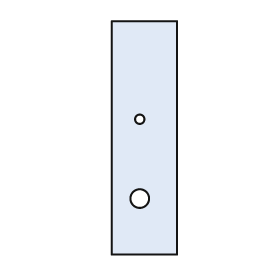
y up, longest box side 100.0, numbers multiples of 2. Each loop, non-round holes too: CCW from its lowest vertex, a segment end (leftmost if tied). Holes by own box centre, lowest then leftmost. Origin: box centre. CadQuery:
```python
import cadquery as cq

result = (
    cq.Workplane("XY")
    .moveTo(-14.0, -50.0)
    .lineTo(14.0, -50.0)
    .lineTo(14.0, 50.0)
    .lineTo(-14.0, 50.0)
    .close()
    .moveTo(-2.0, -26.0)
    .circle(4.0)
    .moveTo(-2.0, 8.0)
    .circle(2.0)
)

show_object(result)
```